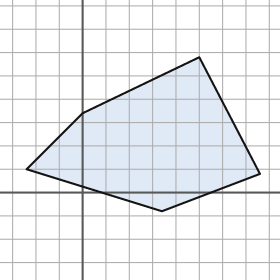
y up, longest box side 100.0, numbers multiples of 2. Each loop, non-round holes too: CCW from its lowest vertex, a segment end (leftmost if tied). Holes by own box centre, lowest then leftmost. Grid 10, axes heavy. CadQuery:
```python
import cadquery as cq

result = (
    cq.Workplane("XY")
    .moveTo(34.0, -8.0)
    .lineTo(76.0, 8.0)
    .lineTo(50.0, 58.0)
    .lineTo(0.0, 34.0)
    .lineTo(-24.0, 10.0)
    .close()
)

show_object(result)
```